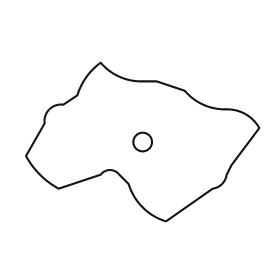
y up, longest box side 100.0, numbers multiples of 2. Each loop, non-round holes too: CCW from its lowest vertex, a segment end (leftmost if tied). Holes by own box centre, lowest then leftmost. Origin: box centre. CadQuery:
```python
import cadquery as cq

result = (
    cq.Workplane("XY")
    .moveTo(10.0, -34.0)
    .lineTo(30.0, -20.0)
    .threePointArc((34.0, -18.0), (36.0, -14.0))
    .lineTo(38.0, -10.0)
    .lineTo(50.0, 6.0)
    .threePointArc((44.0, 12.0), (36.0, 14.0))
    .threePointArc((26.0, 16.0), (18.0, 22.0))
    .lineTo(6.0, 26.0)
    .lineTo(0.0, 26.0)
    .threePointArc((-10.0, 28.0), (-18.0, 34.0))
    .threePointArc((-24.0, 28.0), (-28.0, 20.0))
    .lineTo(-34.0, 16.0)
    .threePointArc((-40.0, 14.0), (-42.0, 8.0))
    .lineTo(-50.0, -6.0)
    .threePointArc((-44.0, -14.0), (-36.0, -20.0))
    .lineTo(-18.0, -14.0)
    .threePointArc((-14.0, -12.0), (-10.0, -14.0))
    .lineTo(-6.0, -18.0)
    .threePointArc((0.0, -28.0), (10.0, -34.0))
    .close()
    .moveTo(0.0, 0.0)
    .circle(4.0)
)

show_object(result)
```